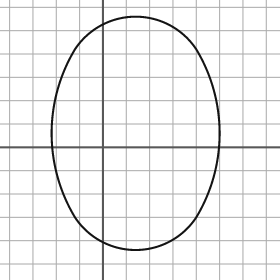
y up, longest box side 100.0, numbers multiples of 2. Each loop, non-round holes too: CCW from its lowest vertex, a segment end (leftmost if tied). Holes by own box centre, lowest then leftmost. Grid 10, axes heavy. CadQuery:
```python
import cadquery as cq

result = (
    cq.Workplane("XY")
    .moveTo(-12.0, -30.0)
    .threePointArc((14.0, -44.0), (40.0, -30.0))
    .threePointArc((50.0, 6.0), (40.0, 42.0))
    .threePointArc((14.0, 56.0), (-12.0, 42.0))
    .threePointArc((-22.0, 6.0), (-12.0, -30.0))
    .close()
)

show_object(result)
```